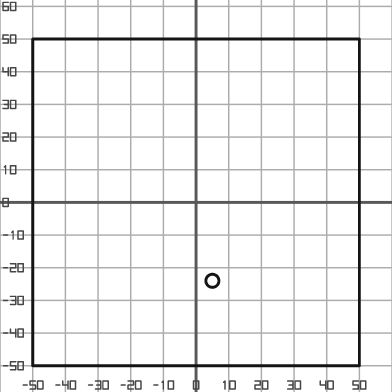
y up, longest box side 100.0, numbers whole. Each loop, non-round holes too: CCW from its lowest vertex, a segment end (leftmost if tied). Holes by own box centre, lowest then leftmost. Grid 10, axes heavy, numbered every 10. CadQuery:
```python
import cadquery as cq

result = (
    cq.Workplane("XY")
    .moveTo(-50.0, -50.0)
    .lineTo(50.0, -50.0)
    .lineTo(50.0, 50.0)
    .lineTo(-50.0, 50.0)
    .close()
    .moveTo(5.0, -24.0)
    .circle(2.0)
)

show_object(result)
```